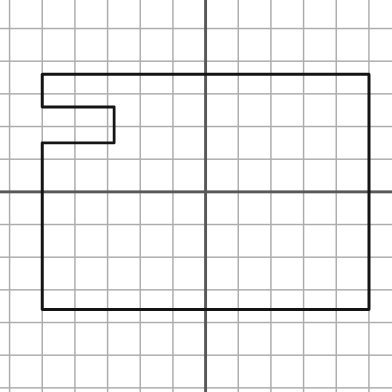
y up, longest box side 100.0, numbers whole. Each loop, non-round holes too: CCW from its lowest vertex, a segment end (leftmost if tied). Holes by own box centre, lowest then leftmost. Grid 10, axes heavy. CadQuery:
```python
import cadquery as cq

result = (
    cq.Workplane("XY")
    .moveTo(-50.0, -36.0)
    .lineTo(50.0, -36.0)
    .lineTo(50.0, 36.0)
    .lineTo(-50.0, 36.0)
    .lineTo(-50.0, 26.0)
    .lineTo(-28.0, 26.0)
    .lineTo(-28.0, 15.0)
    .lineTo(-50.0, 15.0)
    .close()
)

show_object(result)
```